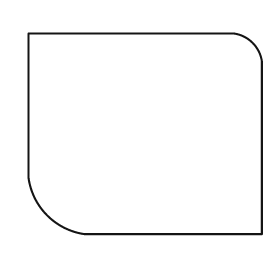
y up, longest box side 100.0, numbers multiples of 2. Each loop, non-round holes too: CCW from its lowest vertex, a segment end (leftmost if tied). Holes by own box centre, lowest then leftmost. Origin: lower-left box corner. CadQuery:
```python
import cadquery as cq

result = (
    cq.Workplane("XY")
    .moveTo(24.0, 0.0)
    .lineTo(100.0, 0.0)
    .lineTo(100.0, 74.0)
    .threePointArc((96.0, 82.0), (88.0, 86.0))
    .lineTo(0.0, 86.0)
    .lineTo(0.0, 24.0)
    .threePointArc((8.0, 8.0), (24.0, 0.0))
    .close()
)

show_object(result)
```